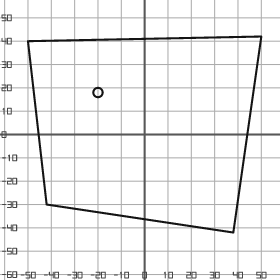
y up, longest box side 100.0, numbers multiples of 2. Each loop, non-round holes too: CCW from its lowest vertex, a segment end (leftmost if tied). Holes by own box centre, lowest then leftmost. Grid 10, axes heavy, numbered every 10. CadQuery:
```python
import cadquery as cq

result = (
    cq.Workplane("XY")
    .moveTo(38.0, -42.0)
    .lineTo(50.0, 42.0)
    .lineTo(-50.0, 40.0)
    .lineTo(-42.0, -30.0)
    .close()
    .moveTo(-20.0, 18.0)
    .circle(2.0)
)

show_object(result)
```